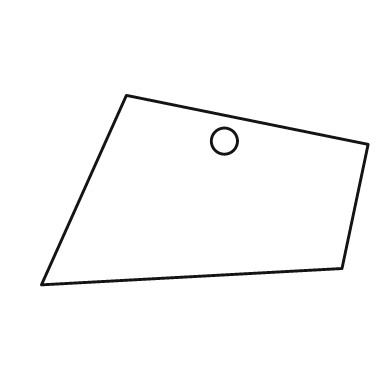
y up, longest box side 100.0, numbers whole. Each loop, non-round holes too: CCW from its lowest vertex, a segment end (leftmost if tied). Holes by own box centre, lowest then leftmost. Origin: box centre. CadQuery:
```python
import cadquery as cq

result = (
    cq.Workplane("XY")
    .moveTo(-50.0, -29.0)
    .lineTo(42.0, -24.0)
    .lineTo(50.0, 14.0)
    .lineTo(-24.0, 29.0)
    .close()
    .moveTo(6.0, 15.0)
    .circle(4.0)
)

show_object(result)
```